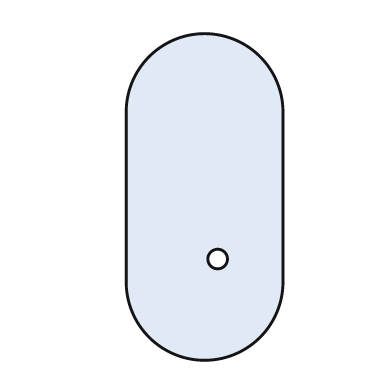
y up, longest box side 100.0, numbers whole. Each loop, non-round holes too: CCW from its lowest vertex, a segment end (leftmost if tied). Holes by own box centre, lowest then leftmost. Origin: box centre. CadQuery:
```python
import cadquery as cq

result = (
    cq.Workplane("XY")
    .moveTo(-24.0, -26.0)
    .threePointArc((0.0, -50.0), (24.0, -26.0))
    .lineTo(24.0, 26.0)
    .threePointArc((0.0, 50.0), (-24.0, 26.0))
    .close()
    .moveTo(4.0, -19.0)
    .circle(3.0)
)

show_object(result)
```